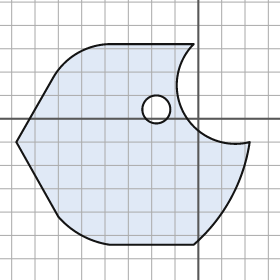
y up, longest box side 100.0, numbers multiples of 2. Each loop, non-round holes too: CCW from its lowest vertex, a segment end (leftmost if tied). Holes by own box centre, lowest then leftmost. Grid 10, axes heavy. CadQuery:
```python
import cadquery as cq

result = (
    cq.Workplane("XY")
    .moveTo(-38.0, -54.0)
    .lineTo(-2.0, -54.0)
    .threePointArc((14.0, -34.0), (22.0, -10.0))
    .threePointArc((-6.0, 2.0), (-2.0, 32.0))
    .lineTo(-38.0, 32.0)
    .threePointArc((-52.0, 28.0), (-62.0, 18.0))
    .lineTo(-78.0, -10.0)
    .lineTo(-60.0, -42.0)
    .threePointArc((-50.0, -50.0), (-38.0, -54.0))
    .close()
    .moveTo(-18.0, 4.0)
    .circle(6.0)
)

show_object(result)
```